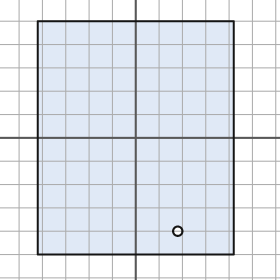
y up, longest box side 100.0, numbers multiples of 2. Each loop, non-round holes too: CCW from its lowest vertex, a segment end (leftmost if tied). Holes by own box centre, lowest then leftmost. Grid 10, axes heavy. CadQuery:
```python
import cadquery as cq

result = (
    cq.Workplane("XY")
    .moveTo(-42.0, -50.0)
    .lineTo(42.0, -50.0)
    .lineTo(42.0, 50.0)
    .lineTo(-42.0, 50.0)
    .close()
    .moveTo(18.0, -40.0)
    .circle(2.0)
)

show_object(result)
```